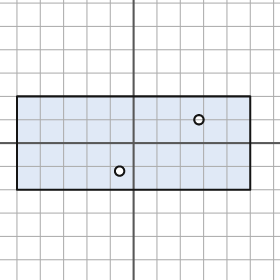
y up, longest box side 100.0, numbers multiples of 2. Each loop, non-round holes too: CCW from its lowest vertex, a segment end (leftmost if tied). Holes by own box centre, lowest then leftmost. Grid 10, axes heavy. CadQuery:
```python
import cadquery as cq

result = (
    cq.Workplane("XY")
    .moveTo(-50.0, -20.0)
    .lineTo(50.0, -20.0)
    .lineTo(50.0, 20.0)
    .lineTo(-50.0, 20.0)
    .close()
    .moveTo(-6.0, -12.0)
    .circle(2.0)
    .moveTo(28.0, 10.0)
    .circle(2.0)
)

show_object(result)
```